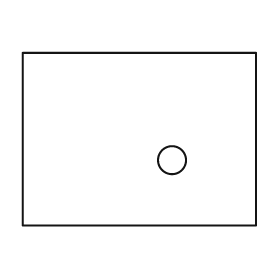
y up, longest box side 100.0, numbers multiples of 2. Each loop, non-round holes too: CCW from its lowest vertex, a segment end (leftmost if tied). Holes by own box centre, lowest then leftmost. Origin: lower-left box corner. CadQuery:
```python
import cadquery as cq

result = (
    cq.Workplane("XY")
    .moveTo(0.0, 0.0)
    .lineTo(100.0, 0.0)
    .lineTo(100.0, 74.0)
    .lineTo(0.0, 74.0)
    .close()
    .moveTo(64.0, 28.0)
    .circle(6.0)
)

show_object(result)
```